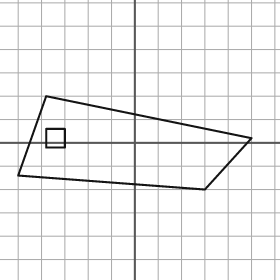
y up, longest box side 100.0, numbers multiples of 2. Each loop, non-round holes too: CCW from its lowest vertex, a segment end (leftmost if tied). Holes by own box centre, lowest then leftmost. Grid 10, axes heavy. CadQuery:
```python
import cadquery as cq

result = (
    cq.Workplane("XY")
    .moveTo(30.0, -20.0)
    .lineTo(50.0, 2.0)
    .lineTo(-38.0, 20.0)
    .lineTo(-50.0, -14.0)
    .close()
    .moveTo(-38.0, -2.0)
    .lineTo(-30.0, -2.0)
    .lineTo(-30.0, 6.0)
    .lineTo(-38.0, 6.0)
    .close()
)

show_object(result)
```